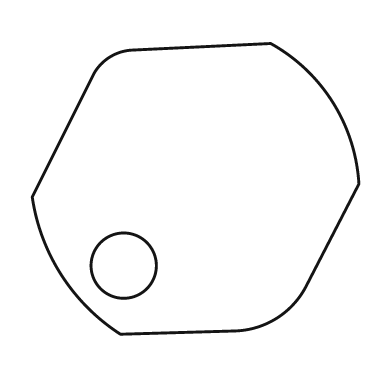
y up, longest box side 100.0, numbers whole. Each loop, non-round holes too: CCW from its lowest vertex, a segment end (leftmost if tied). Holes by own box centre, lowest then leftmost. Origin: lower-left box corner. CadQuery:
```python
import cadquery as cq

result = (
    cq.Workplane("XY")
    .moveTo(27.0, 0.0)
    .lineTo(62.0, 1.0)
    .threePointArc((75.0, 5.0), (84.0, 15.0))
    .lineTo(100.0, 46.0)
    .threePointArc((92.0, 71.0), (73.0, 89.0))
    .lineTo(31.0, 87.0)
    .threePointArc((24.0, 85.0), (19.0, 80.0))
    .lineTo(0.0, 42.0)
    .threePointArc((9.0, 18.0), (27.0, 0.0))
    .close()
    .moveTo(28.0, 21.0)
    .circle(10.0)
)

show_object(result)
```